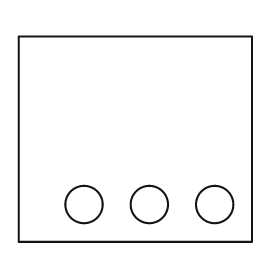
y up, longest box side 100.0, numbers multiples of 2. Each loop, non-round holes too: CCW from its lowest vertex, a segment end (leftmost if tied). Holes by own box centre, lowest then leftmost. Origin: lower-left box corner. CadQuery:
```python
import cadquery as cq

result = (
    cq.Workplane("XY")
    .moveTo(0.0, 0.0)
    .lineTo(100.0, 0.0)
    .lineTo(100.0, 88.0)
    .lineTo(0.0, 88.0)
    .close()
    .moveTo(28.0, 16.0)
    .circle(8.0)
    .moveTo(56.0, 16.0)
    .circle(8.0)
    .moveTo(84.0, 16.0)
    .circle(8.0)
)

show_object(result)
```